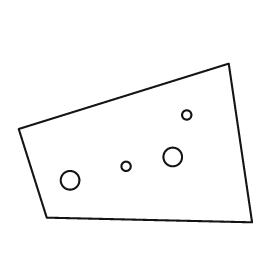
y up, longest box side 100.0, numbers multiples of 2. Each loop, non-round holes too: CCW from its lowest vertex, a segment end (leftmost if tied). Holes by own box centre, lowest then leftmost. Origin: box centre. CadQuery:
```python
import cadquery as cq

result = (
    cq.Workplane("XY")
    .moveTo(50.0, -34.0)
    .lineTo(40.0, 34.0)
    .lineTo(-50.0, 6.0)
    .lineTo(-38.0, -32.0)
    .close()
    .moveTo(-28.0, -16.0)
    .circle(4.0)
    .moveTo(-4.0, -10.0)
    .circle(2.0)
    .moveTo(16.0, -6.0)
    .circle(4.0)
    .moveTo(22.0, 12.0)
    .circle(2.0)
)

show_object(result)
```